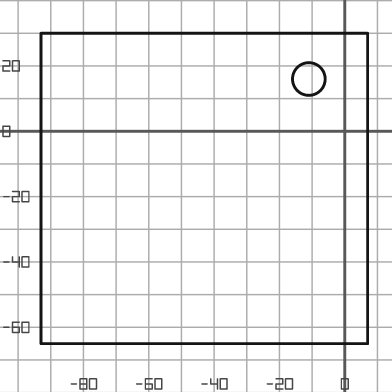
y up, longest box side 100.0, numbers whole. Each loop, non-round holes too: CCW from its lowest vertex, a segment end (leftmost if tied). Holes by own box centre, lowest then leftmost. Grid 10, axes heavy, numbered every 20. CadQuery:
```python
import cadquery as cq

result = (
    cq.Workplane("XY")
    .moveTo(-93.0, -65.0)
    .lineTo(7.0, -65.0)
    .lineTo(7.0, 30.0)
    .lineTo(-93.0, 30.0)
    .close()
    .moveTo(-11.0, 16.0)
    .circle(5.0)
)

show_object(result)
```